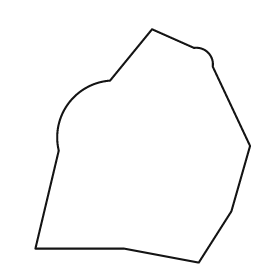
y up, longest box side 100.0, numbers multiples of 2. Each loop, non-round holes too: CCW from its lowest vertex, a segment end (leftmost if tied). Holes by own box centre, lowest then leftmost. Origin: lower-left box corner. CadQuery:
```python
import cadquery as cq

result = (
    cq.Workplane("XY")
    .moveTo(70.0, 0.0)
    .lineTo(84.0, 22.0)
    .lineTo(92.0, 50.0)
    .lineTo(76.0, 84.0)
    .threePointArc((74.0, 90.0), (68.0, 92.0))
    .lineTo(50.0, 100.0)
    .lineTo(32.0, 78.0)
    .threePointArc((14.0, 68.0), (10.0, 48.0))
    .lineTo(0.0, 6.0)
    .lineTo(38.0, 6.0)
    .close()
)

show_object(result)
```